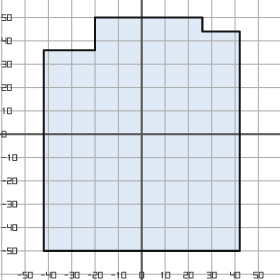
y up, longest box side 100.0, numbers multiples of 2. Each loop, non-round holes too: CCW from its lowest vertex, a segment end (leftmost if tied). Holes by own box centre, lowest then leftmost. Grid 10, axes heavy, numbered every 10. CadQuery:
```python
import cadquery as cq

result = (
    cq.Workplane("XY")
    .moveTo(-42.0, -50.0)
    .lineTo(42.0, -50.0)
    .lineTo(42.0, 44.0)
    .lineTo(26.0, 44.0)
    .lineTo(26.0, 50.0)
    .lineTo(-20.0, 50.0)
    .lineTo(-20.0, 36.0)
    .lineTo(-42.0, 36.0)
    .close()
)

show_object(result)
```